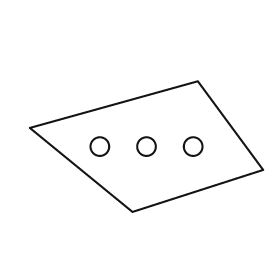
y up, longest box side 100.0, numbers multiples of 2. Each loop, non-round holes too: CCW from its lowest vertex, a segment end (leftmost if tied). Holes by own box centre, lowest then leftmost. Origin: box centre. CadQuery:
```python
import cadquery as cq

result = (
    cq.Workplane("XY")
    .moveTo(-6.0, -28.0)
    .lineTo(50.0, -10.0)
    .lineTo(22.0, 28.0)
    .lineTo(-50.0, 8.0)
    .close()
    .moveTo(-20.0, 0.0)
    .circle(4.0)
    .moveTo(0.0, 0.0)
    .circle(4.0)
    .moveTo(20.0, 0.0)
    .circle(4.0)
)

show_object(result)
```